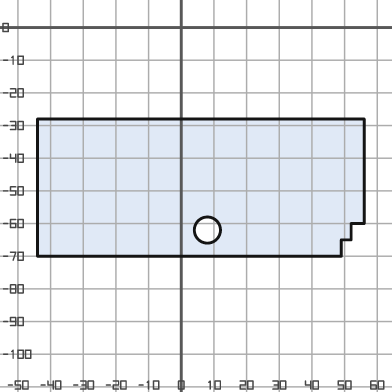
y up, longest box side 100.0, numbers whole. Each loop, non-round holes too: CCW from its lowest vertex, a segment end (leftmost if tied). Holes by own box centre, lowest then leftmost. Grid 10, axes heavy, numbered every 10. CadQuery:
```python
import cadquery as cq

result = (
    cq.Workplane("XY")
    .moveTo(-44.0, -70.0)
    .lineTo(49.0, -70.0)
    .lineTo(49.0, -65.0)
    .lineTo(52.0, -65.0)
    .lineTo(52.0, -60.0)
    .lineTo(56.0, -60.0)
    .lineTo(56.0, -28.0)
    .lineTo(-44.0, -28.0)
    .close()
    .moveTo(8.0, -62.0)
    .circle(4.0)
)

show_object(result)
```